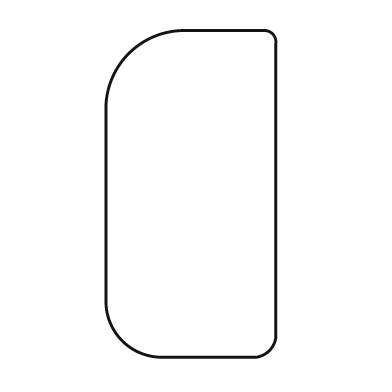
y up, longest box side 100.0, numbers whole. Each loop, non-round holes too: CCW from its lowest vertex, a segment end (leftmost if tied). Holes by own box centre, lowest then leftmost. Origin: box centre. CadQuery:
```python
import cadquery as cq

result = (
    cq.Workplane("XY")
    .moveTo(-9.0, -50.0)
    .lineTo(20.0, -50.0)
    .threePointArc((24.0, -48.0), (26.0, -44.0))
    .lineTo(26.0, 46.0)
    .threePointArc((25.0, 49.0), (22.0, 50.0))
    .lineTo(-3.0, 50.0)
    .threePointArc((-19.0, 43.0), (-26.0, 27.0))
    .lineTo(-26.0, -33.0)
    .threePointArc((-21.0, -45.0), (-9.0, -50.0))
    .close()
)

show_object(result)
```